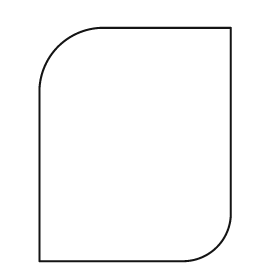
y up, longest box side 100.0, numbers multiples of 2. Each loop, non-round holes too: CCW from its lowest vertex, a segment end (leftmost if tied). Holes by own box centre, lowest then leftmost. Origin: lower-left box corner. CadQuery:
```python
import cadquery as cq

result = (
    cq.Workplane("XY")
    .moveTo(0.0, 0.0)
    .lineTo(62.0, 0.0)
    .threePointArc((76.0, 6.0), (82.0, 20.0))
    .lineTo(82.0, 100.0)
    .lineTo(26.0, 100.0)
    .threePointArc((8.0, 92.0), (0.0, 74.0))
    .close()
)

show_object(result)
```